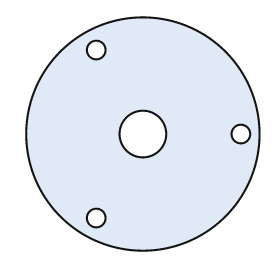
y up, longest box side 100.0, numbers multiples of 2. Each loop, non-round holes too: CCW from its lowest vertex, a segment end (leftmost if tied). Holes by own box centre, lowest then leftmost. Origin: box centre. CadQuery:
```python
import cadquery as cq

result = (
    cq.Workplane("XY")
    .moveTo(0.0, 0.0)
    .circle(50.0)
    .moveTo(-20.0, -36.0)
    .circle(4.0)
    .moveTo(0.0, 0.0)
    .circle(10.0)
    .moveTo(42.0, 0.0)
    .circle(4.0)
    .moveTo(-20.0, 36.0)
    .circle(4.0)
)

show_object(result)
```